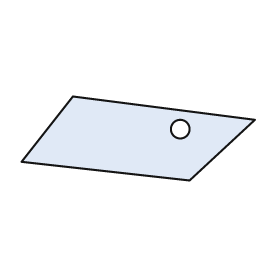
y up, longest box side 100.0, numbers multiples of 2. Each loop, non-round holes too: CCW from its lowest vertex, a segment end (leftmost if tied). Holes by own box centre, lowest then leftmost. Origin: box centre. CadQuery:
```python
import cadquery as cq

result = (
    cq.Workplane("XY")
    .moveTo(22.0, -18.0)
    .lineTo(50.0, 8.0)
    .lineTo(-28.0, 18.0)
    .lineTo(-50.0, -10.0)
    .close()
    .moveTo(18.0, 4.0)
    .circle(4.0)
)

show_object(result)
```